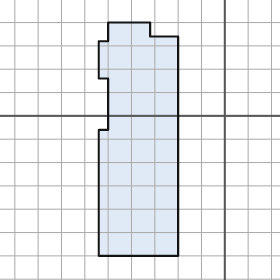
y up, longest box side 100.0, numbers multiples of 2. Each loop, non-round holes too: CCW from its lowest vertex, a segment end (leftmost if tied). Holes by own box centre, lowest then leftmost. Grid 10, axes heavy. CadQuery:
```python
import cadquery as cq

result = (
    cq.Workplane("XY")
    .moveTo(-54.0, -60.0)
    .lineTo(-20.0, -60.0)
    .lineTo(-20.0, 34.0)
    .lineTo(-32.0, 34.0)
    .lineTo(-32.0, 40.0)
    .lineTo(-50.0, 40.0)
    .lineTo(-50.0, 32.0)
    .lineTo(-54.0, 32.0)
    .lineTo(-54.0, 16.0)
    .lineTo(-50.0, 16.0)
    .lineTo(-50.0, -6.0)
    .lineTo(-54.0, -6.0)
    .close()
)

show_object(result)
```